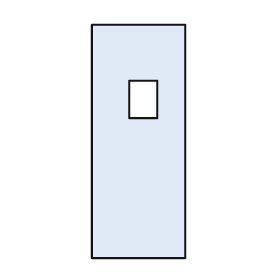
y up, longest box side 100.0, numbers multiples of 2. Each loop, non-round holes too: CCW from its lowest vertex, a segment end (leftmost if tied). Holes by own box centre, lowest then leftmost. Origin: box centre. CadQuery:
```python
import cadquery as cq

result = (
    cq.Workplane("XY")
    .moveTo(-20.0, -50.0)
    .lineTo(20.0, -50.0)
    .lineTo(20.0, 50.0)
    .lineTo(-20.0, 50.0)
    .close()
    .moveTo(-4.0, 10.0)
    .lineTo(8.0, 10.0)
    .lineTo(8.0, 26.0)
    .lineTo(-4.0, 26.0)
    .close()
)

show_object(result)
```